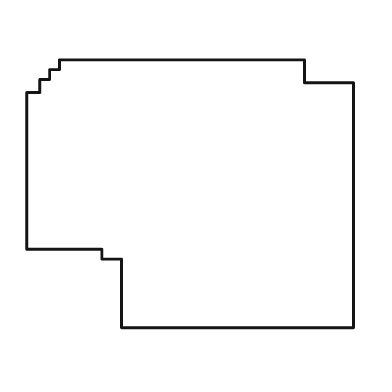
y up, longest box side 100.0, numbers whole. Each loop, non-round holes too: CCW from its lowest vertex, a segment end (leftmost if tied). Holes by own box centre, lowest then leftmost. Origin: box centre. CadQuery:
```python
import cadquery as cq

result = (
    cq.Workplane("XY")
    .moveTo(-21.0, -41.0)
    .lineTo(50.0, -41.0)
    .lineTo(50.0, 34.0)
    .lineTo(35.0, 34.0)
    .lineTo(35.0, 41.0)
    .lineTo(-40.0, 41.0)
    .lineTo(-40.0, 38.0)
    .lineTo(-43.0, 38.0)
    .lineTo(-43.0, 35.0)
    .lineTo(-46.0, 35.0)
    .lineTo(-46.0, 31.0)
    .lineTo(-50.0, 31.0)
    .lineTo(-50.0, -17.0)
    .lineTo(-27.0, -17.0)
    .lineTo(-27.0, -20.0)
    .lineTo(-21.0, -20.0)
    .close()
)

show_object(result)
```